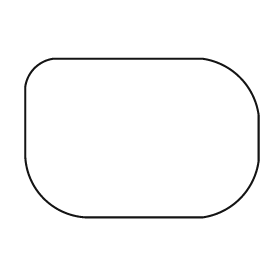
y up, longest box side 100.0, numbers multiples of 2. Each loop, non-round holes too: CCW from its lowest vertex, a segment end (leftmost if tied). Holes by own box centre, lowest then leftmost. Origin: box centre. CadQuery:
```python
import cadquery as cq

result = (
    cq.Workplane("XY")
    .moveTo(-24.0, -34.0)
    .lineTo(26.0, -34.0)
    .threePointArc((42.0, -26.0), (50.0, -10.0))
    .lineTo(50.0, 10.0)
    .threePointArc((42.0, 26.0), (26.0, 34.0))
    .lineTo(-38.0, 34.0)
    .threePointArc((-46.0, 30.0), (-50.0, 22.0))
    .lineTo(-50.0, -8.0)
    .threePointArc((-42.0, -26.0), (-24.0, -34.0))
    .close()
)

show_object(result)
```